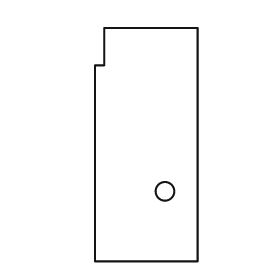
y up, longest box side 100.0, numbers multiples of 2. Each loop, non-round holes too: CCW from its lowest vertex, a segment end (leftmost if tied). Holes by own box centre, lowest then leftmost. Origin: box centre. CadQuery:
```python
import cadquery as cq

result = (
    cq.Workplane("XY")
    .moveTo(-22.0, -50.0)
    .lineTo(22.0, -50.0)
    .lineTo(22.0, 50.0)
    .lineTo(-18.0, 50.0)
    .lineTo(-18.0, 34.0)
    .lineTo(-22.0, 34.0)
    .close()
    .moveTo(8.0, -20.0)
    .circle(4.0)
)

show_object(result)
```